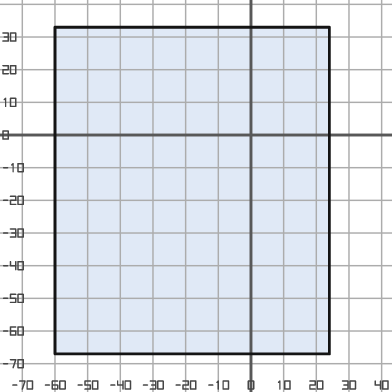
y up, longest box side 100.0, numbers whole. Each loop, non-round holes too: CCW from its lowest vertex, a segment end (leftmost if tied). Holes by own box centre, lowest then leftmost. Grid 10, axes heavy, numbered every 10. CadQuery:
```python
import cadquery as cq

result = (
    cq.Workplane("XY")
    .moveTo(-60.0, -67.0)
    .lineTo(24.0, -67.0)
    .lineTo(24.0, 33.0)
    .lineTo(-60.0, 33.0)
    .close()
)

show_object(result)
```